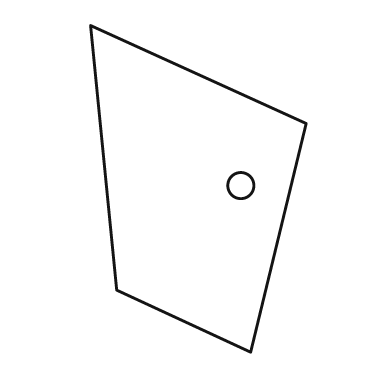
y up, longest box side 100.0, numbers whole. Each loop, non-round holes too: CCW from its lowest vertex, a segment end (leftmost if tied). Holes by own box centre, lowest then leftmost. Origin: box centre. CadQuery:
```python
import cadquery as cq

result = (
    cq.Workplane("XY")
    .moveTo(16.0, -50.0)
    .lineTo(33.0, 20.0)
    .lineTo(-33.0, 50.0)
    .lineTo(-25.0, -31.0)
    .close()
    .moveTo(13.0, 1.0)
    .circle(4.0)
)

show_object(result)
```